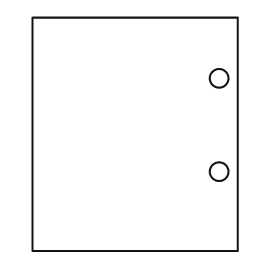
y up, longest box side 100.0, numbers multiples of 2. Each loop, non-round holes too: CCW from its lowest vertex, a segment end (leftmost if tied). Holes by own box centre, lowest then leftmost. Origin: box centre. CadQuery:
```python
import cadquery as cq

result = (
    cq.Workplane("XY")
    .moveTo(-44.0, -50.0)
    .lineTo(44.0, -50.0)
    .lineTo(44.0, 50.0)
    .lineTo(-44.0, 50.0)
    .close()
    .moveTo(36.0, -16.0)
    .circle(4.0)
    .moveTo(36.0, 24.0)
    .circle(4.0)
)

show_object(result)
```